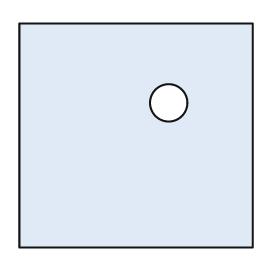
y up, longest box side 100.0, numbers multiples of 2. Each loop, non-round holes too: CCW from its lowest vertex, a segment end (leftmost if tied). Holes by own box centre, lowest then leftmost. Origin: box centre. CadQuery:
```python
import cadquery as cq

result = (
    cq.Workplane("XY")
    .moveTo(-50.0, -48.0)
    .lineTo(50.0, -48.0)
    .lineTo(50.0, 48.0)
    .lineTo(-50.0, 48.0)
    .close()
    .moveTo(14.0, 14.0)
    .circle(8.0)
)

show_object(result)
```